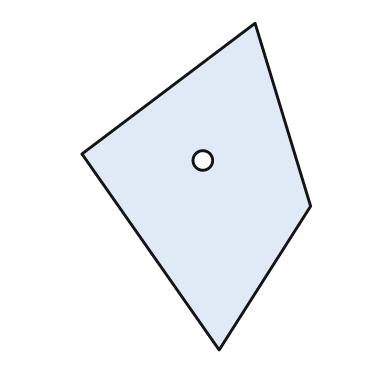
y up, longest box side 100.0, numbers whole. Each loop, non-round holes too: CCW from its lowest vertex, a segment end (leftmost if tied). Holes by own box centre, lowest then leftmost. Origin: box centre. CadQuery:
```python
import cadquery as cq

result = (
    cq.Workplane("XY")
    .moveTo(7.0, -50.0)
    .lineTo(35.0, -6.0)
    .lineTo(18.0, 50.0)
    .lineTo(-35.0, 10.0)
    .close()
    .moveTo(2.0, 8.0)
    .circle(3.0)
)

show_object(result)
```